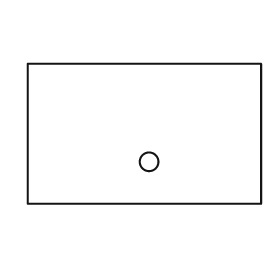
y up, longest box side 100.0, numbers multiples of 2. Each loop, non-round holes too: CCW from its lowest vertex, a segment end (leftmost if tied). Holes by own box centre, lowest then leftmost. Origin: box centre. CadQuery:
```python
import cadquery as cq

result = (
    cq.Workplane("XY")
    .moveTo(-50.0, -30.0)
    .lineTo(50.0, -30.0)
    .lineTo(50.0, 30.0)
    .lineTo(-50.0, 30.0)
    .close()
    .moveTo(2.0, -12.0)
    .circle(4.0)
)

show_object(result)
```